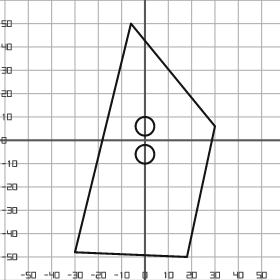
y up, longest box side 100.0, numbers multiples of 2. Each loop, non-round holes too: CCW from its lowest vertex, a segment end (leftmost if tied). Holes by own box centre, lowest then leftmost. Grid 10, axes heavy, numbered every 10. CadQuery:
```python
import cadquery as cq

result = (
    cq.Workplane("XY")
    .moveTo(18.0, -50.0)
    .lineTo(30.0, 6.0)
    .lineTo(-6.0, 50.0)
    .lineTo(-30.0, -48.0)
    .close()
    .moveTo(0.0, -6.0)
    .circle(4.0)
    .moveTo(0.0, 6.0)
    .circle(4.0)
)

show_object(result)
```